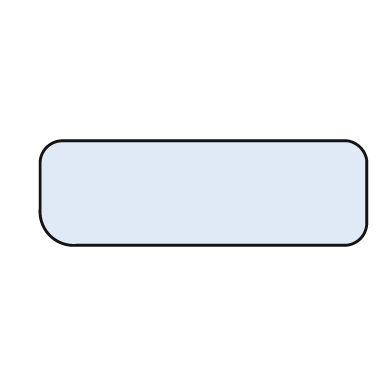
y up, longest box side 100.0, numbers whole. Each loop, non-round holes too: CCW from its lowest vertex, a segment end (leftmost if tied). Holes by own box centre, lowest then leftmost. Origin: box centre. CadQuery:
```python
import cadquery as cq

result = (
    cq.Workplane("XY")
    .moveTo(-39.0, -16.0)
    .lineTo(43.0, -16.0)
    .threePointArc((48.0, -14.0), (50.0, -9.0))
    .lineTo(50.0, 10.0)
    .threePointArc((48.0, 14.0), (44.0, 16.0))
    .lineTo(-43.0, 16.0)
    .threePointArc((-48.0, 14.0), (-50.0, 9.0))
    .lineTo(-50.0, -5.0)
    .threePointArc((-47.0, -13.0), (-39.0, -16.0))
    .close()
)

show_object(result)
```